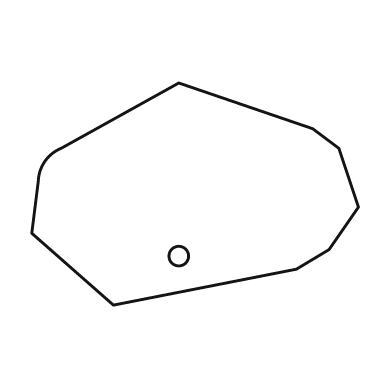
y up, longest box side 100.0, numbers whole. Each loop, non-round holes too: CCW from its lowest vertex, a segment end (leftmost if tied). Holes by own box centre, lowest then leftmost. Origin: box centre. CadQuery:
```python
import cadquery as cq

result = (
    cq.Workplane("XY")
    .moveTo(-25.0, -34.0)
    .lineTo(31.0, -23.0)
    .lineTo(41.0, -17.0)
    .lineTo(50.0, -4.0)
    .lineTo(44.0, 14.0)
    .lineTo(36.0, 20.0)
    .lineTo(-5.0, 34.0)
    .lineTo(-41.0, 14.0)
    .threePointArc((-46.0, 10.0), (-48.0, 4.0))
    .lineTo(-50.0, -12.0)
    .close()
    .moveTo(-5.0, -19.0)
    .circle(3.0)
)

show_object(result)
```